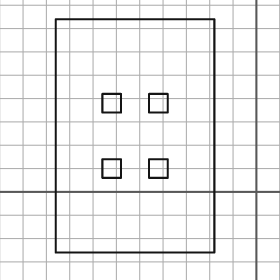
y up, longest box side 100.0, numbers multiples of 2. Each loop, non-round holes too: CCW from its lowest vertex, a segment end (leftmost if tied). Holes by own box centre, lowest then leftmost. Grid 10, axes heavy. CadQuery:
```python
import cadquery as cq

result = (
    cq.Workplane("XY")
    .moveTo(-86.0, -26.0)
    .lineTo(-18.0, -26.0)
    .lineTo(-18.0, 74.0)
    .lineTo(-86.0, 74.0)
    .close()
    .moveTo(-66.0, 6.0)
    .lineTo(-58.0, 6.0)
    .lineTo(-58.0, 14.0)
    .lineTo(-66.0, 14.0)
    .close()
    .moveTo(-46.0, 6.0)
    .lineTo(-38.0, 6.0)
    .lineTo(-38.0, 14.0)
    .lineTo(-46.0, 14.0)
    .close()
    .moveTo(-66.0, 34.0)
    .lineTo(-58.0, 34.0)
    .lineTo(-58.0, 42.0)
    .lineTo(-66.0, 42.0)
    .close()
    .moveTo(-46.0, 34.0)
    .lineTo(-38.0, 34.0)
    .lineTo(-38.0, 42.0)
    .lineTo(-46.0, 42.0)
    .close()
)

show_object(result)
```